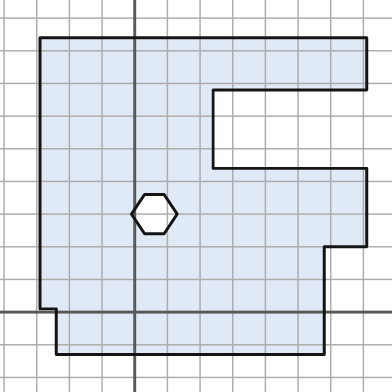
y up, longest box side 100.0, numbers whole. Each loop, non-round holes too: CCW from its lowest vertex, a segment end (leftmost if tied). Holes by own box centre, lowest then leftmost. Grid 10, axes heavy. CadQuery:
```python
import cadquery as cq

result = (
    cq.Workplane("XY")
    .moveTo(-24.0, -13.0)
    .lineTo(58.0, -13.0)
    .lineTo(58.0, 20.0)
    .lineTo(71.0, 20.0)
    .lineTo(71.0, 44.0)
    .lineTo(24.0, 44.0)
    .lineTo(24.0, 68.0)
    .lineTo(71.0, 68.0)
    .lineTo(71.0, 84.0)
    .lineTo(-29.0, 84.0)
    .lineTo(-29.0, 1.0)
    .lineTo(-24.0, 1.0)
    .close()
    .moveTo(3.0, 24.0)
    .lineTo(9.0, 24.0)
    .lineTo(13.0, 30.0)
    .lineTo(9.0, 36.0)
    .lineTo(3.0, 36.0)
    .lineTo(-1.0, 30.0)
    .close()
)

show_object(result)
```